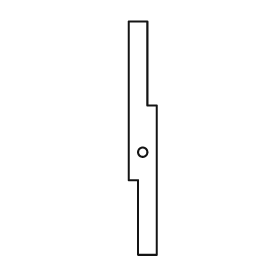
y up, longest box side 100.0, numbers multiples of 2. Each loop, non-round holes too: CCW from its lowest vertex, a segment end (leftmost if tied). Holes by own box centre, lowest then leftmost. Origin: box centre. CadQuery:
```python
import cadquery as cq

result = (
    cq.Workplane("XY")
    .moveTo(-2.0, -50.0)
    .lineTo(6.0, -50.0)
    .lineTo(6.0, 14.0)
    .lineTo(2.0, 14.0)
    .lineTo(2.0, 50.0)
    .lineTo(-6.0, 50.0)
    .lineTo(-6.0, -18.0)
    .lineTo(-2.0, -18.0)
    .close()
    .moveTo(0.0, -6.0)
    .circle(2.0)
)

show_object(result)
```